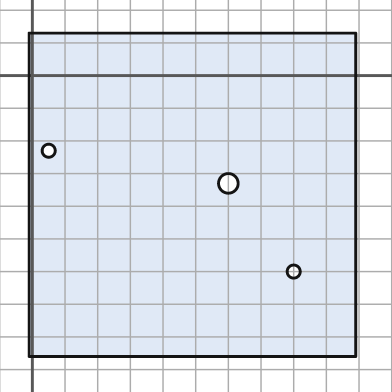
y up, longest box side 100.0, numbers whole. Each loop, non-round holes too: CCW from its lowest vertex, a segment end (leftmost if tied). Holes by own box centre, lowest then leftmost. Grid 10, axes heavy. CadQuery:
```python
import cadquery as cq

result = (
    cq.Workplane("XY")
    .moveTo(-1.0, -86.0)
    .lineTo(99.0, -86.0)
    .lineTo(99.0, 13.0)
    .lineTo(-1.0, 13.0)
    .close()
    .moveTo(80.0, -60.0)
    .circle(2.0)
    .moveTo(60.0, -33.0)
    .circle(3.0)
    .moveTo(5.0, -23.0)
    .circle(2.0)
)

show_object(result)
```